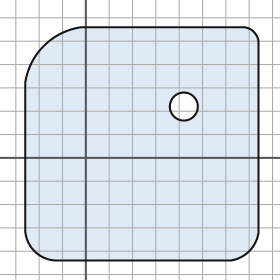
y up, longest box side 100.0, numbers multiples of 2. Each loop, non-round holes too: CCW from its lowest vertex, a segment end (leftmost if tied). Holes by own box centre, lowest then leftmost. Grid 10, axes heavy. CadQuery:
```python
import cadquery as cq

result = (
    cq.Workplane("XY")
    .moveTo(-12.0, -44.0)
    .lineTo(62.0, -44.0)
    .threePointArc((70.0, -40.0), (74.0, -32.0))
    .lineTo(74.0, 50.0)
    .threePointArc((72.0, 54.0), (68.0, 56.0))
    .lineTo(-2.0, 56.0)
    .threePointArc((-18.0, 48.0), (-26.0, 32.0))
    .lineTo(-26.0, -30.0)
    .threePointArc((-22.0, -40.0), (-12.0, -44.0))
    .close()
    .moveTo(42.0, 22.0)
    .circle(6.0)
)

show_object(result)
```